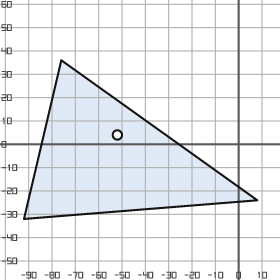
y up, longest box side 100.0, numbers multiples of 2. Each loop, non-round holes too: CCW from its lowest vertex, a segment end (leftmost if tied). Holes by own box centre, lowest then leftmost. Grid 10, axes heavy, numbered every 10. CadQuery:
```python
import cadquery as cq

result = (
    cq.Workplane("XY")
    .moveTo(-92.0, -32.0)
    .lineTo(8.0, -24.0)
    .lineTo(-76.0, 36.0)
    .close()
    .moveTo(-52.0, 4.0)
    .circle(2.0)
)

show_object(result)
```